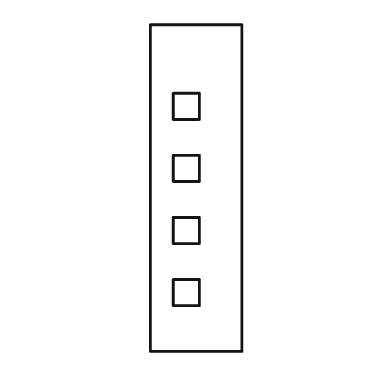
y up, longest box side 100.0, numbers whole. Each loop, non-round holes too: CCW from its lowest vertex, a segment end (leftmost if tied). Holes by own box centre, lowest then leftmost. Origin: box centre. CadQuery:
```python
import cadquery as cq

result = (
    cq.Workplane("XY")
    .moveTo(-14.0, -50.0)
    .lineTo(14.0, -50.0)
    .lineTo(14.0, 50.0)
    .lineTo(-14.0, 50.0)
    .close()
    .moveTo(-7.0, -36.0)
    .lineTo(1.0, -36.0)
    .lineTo(1.0, -28.0)
    .lineTo(-7.0, -28.0)
    .close()
    .moveTo(-7.0, -17.0)
    .lineTo(1.0, -17.0)
    .lineTo(1.0, -9.0)
    .lineTo(-7.0, -9.0)
    .close()
    .moveTo(-7.0, 2.0)
    .lineTo(1.0, 2.0)
    .lineTo(1.0, 10.0)
    .lineTo(-7.0, 10.0)
    .close()
    .moveTo(-7.0, 21.0)
    .lineTo(1.0, 21.0)
    .lineTo(1.0, 29.0)
    .lineTo(-7.0, 29.0)
    .close()
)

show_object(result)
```